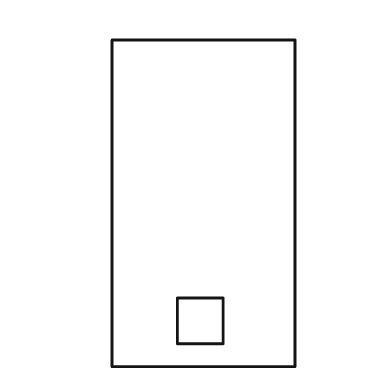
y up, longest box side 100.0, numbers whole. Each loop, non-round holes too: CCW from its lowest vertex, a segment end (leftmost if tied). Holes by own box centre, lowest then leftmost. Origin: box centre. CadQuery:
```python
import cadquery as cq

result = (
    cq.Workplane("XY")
    .moveTo(-28.0, -50.0)
    .lineTo(28.0, -50.0)
    .lineTo(28.0, 50.0)
    .lineTo(-28.0, 50.0)
    .close()
    .moveTo(-8.0, -43.0)
    .lineTo(6.0, -43.0)
    .lineTo(6.0, -29.0)
    .lineTo(-8.0, -29.0)
    .close()
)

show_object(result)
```